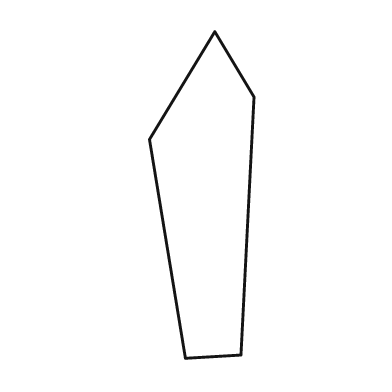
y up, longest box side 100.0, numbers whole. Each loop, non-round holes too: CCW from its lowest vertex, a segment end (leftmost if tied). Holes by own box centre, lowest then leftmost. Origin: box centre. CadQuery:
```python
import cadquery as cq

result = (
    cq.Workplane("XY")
    .moveTo(-5.0, -50.0)
    .lineTo(12.0, -49.0)
    .lineTo(16.0, 30.0)
    .lineTo(4.0, 50.0)
    .lineTo(-16.0, 17.0)
    .close()
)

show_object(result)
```